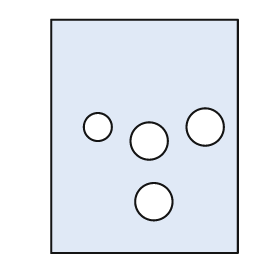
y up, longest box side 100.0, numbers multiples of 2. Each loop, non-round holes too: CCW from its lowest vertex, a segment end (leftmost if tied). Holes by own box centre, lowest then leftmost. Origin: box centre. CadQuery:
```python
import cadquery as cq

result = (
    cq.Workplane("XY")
    .moveTo(-40.0, -50.0)
    .lineTo(40.0, -50.0)
    .lineTo(40.0, 50.0)
    .lineTo(-40.0, 50.0)
    .close()
    .moveTo(4.0, -28.0)
    .circle(8.0)
    .moveTo(2.0, -2.0)
    .circle(8.0)
    .moveTo(-20.0, 4.0)
    .circle(6.0)
    .moveTo(26.0, 4.0)
    .circle(8.0)
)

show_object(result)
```